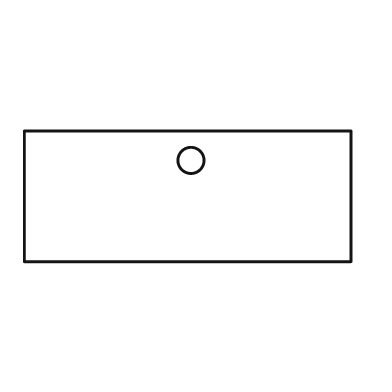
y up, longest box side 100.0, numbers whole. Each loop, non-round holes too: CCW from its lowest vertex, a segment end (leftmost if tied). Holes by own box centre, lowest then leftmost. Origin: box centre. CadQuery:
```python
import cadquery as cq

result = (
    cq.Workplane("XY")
    .moveTo(-50.0, -20.0)
    .lineTo(50.0, -20.0)
    .lineTo(50.0, 20.0)
    .lineTo(-50.0, 20.0)
    .close()
    .moveTo(1.0, 11.0)
    .circle(4.0)
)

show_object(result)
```